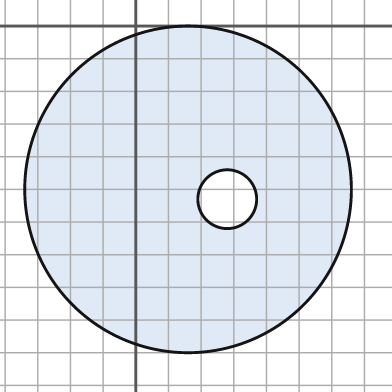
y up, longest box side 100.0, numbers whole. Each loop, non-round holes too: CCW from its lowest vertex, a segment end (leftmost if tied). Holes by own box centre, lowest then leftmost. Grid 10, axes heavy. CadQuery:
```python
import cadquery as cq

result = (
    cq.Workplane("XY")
    .moveTo(16.0, -50.0)
    .circle(50.0)
    .moveTo(28.0, -53.0)
    .circle(9.0)
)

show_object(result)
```